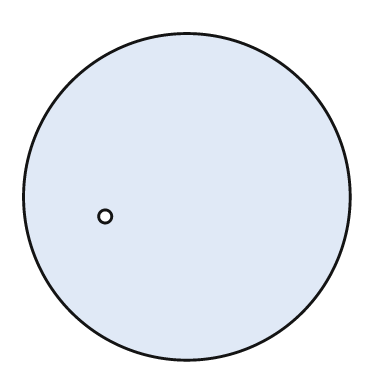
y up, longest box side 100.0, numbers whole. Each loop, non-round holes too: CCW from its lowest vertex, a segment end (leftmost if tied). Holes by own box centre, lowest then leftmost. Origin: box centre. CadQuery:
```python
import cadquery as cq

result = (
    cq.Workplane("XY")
    .moveTo(0.0, 0.0)
    .circle(50.0)
    .moveTo(-25.0, -6.0)
    .circle(2.0)
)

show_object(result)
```